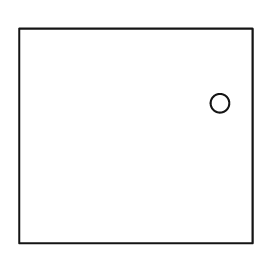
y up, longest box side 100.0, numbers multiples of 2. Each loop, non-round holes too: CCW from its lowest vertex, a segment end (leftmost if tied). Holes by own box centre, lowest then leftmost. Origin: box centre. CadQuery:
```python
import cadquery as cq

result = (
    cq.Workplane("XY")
    .moveTo(-50.0, -46.0)
    .lineTo(50.0, -46.0)
    .lineTo(50.0, 46.0)
    .lineTo(-50.0, 46.0)
    .close()
    .moveTo(36.0, 14.0)
    .circle(4.0)
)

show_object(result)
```